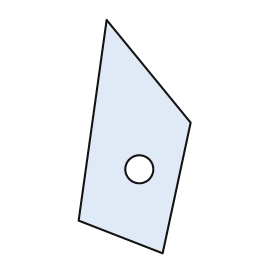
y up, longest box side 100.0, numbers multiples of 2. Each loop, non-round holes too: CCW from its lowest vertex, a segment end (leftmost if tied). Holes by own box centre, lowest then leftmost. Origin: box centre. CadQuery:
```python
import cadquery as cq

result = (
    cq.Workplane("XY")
    .moveTo(12.0, -50.0)
    .lineTo(24.0, 6.0)
    .lineTo(-12.0, 50.0)
    .lineTo(-24.0, -36.0)
    .close()
    .moveTo(2.0, -14.0)
    .circle(6.0)
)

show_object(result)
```